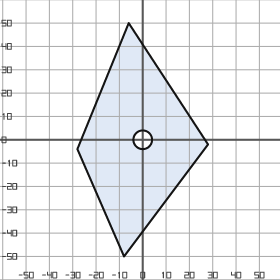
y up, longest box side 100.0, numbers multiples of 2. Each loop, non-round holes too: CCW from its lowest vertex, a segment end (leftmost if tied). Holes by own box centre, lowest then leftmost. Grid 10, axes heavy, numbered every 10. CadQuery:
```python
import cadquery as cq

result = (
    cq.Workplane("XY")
    .moveTo(-8.0, -50.0)
    .lineTo(28.0, -2.0)
    .lineTo(-6.0, 50.0)
    .lineTo(-28.0, -4.0)
    .close()
    .moveTo(0.0, 0.0)
    .circle(4.0)
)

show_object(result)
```